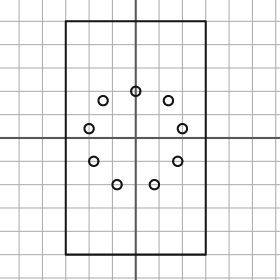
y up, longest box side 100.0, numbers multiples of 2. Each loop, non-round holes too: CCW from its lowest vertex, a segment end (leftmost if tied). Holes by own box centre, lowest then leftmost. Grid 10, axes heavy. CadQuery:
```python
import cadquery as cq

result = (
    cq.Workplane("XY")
    .moveTo(-30.0, -50.0)
    .lineTo(30.0, -50.0)
    .lineTo(30.0, 50.0)
    .lineTo(-30.0, 50.0)
    .close()
    .moveTo(-8.0, -20.0)
    .circle(2.0)
    .moveTo(8.0, -20.0)
    .circle(2.0)
    .moveTo(-18.0, -10.0)
    .circle(2.0)
    .moveTo(18.0, -10.0)
    .circle(2.0)
    .moveTo(-20.0, 4.0)
    .circle(2.0)
    .moveTo(20.0, 4.0)
    .circle(2.0)
    .moveTo(-14.0, 16.0)
    .circle(2.0)
    .moveTo(14.0, 16.0)
    .circle(2.0)
    .moveTo(0.0, 20.0)
    .circle(2.0)
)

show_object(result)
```